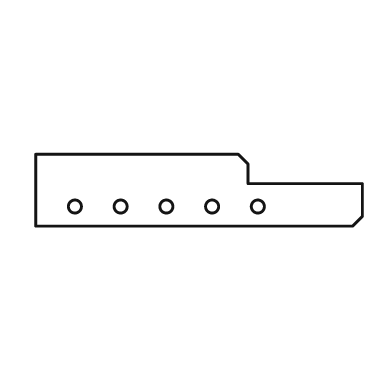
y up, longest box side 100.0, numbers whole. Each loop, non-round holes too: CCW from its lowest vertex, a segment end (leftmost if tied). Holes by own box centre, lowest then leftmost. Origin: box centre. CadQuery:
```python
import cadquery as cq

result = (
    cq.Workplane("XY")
    .moveTo(-50.0, -11.0)
    .lineTo(47.0, -11.0)
    .lineTo(50.0, -8.0)
    .lineTo(50.0, 2.0)
    .lineTo(15.0, 2.0)
    .lineTo(15.0, 8.0)
    .lineTo(12.0, 11.0)
    .lineTo(-50.0, 11.0)
    .close()
    .moveTo(-38.0, -5.0)
    .circle(2.0)
    .moveTo(-24.0, -5.0)
    .circle(2.0)
    .moveTo(-10.0, -5.0)
    .circle(2.0)
    .moveTo(4.0, -5.0)
    .circle(2.0)
    .moveTo(18.0, -5.0)
    .circle(2.0)
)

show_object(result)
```